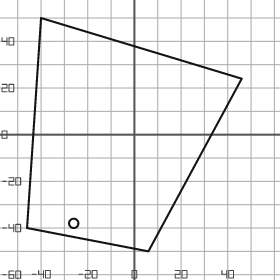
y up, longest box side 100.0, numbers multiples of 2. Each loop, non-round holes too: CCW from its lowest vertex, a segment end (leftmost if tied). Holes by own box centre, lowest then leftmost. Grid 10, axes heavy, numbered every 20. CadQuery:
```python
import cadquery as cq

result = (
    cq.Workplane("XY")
    .moveTo(6.0, -50.0)
    .lineTo(46.0, 24.0)
    .lineTo(-40.0, 50.0)
    .lineTo(-46.0, -40.0)
    .close()
    .moveTo(-26.0, -38.0)
    .circle(2.0)
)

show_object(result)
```